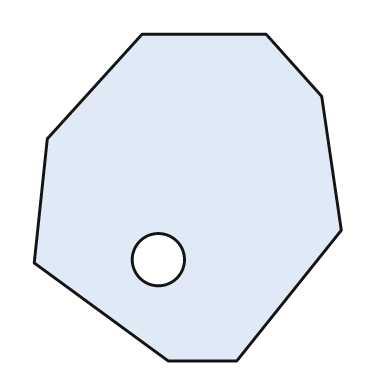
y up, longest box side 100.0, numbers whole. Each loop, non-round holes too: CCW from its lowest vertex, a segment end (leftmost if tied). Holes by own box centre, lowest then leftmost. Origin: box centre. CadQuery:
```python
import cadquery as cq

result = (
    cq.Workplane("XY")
    .moveTo(-6.0, -50.0)
    .lineTo(15.0, -50.0)
    .lineTo(47.0, -10.0)
    .lineTo(41.0, 31.0)
    .lineTo(24.0, 50.0)
    .lineTo(-14.0, 50.0)
    .lineTo(-43.0, 18.0)
    .lineTo(-47.0, -20.0)
    .close()
    .moveTo(-9.0, -19.0)
    .circle(8.0)
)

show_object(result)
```